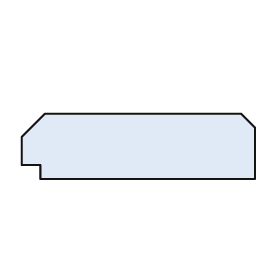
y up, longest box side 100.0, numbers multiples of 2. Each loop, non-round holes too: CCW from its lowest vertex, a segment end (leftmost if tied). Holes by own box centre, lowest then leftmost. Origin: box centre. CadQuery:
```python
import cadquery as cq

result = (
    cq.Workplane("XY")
    .moveTo(-42.0, -14.0)
    .lineTo(50.0, -14.0)
    .lineTo(50.0, 8.0)
    .lineTo(44.0, 14.0)
    .lineTo(-40.0, 14.0)
    .lineTo(-50.0, 4.0)
    .lineTo(-50.0, -8.0)
    .lineTo(-42.0, -8.0)
    .close()
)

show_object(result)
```